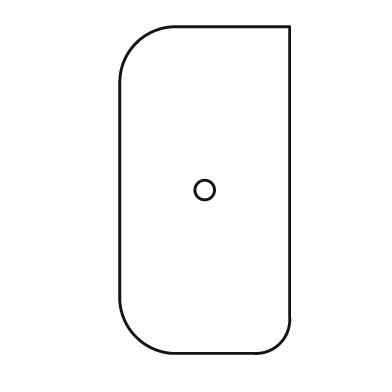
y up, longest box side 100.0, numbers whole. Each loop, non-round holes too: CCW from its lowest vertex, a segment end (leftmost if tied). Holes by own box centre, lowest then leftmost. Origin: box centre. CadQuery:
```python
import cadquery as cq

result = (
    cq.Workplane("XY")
    .moveTo(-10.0, -50.0)
    .lineTo(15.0, -50.0)
    .threePointArc((23.0, -47.0), (26.0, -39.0))
    .lineTo(26.0, 50.0)
    .lineTo(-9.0, 50.0)
    .threePointArc((-21.0, 45.0), (-26.0, 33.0))
    .lineTo(-26.0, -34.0)
    .threePointArc((-21.0, -45.0), (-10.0, -50.0))
    .close()
    .moveTo(0.0, 0.0)
    .circle(3.0)
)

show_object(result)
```